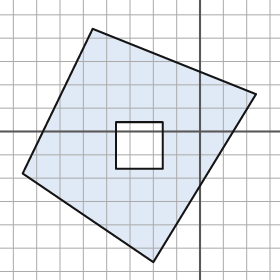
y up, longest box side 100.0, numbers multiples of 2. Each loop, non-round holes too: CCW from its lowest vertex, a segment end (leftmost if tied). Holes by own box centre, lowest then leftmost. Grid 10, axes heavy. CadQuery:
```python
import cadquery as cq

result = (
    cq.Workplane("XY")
    .moveTo(-20.0, -56.0)
    .lineTo(24.0, 16.0)
    .lineTo(-46.0, 44.0)
    .lineTo(-76.0, -18.0)
    .close()
    .moveTo(-36.0, -16.0)
    .lineTo(-16.0, -16.0)
    .lineTo(-16.0, 4.0)
    .lineTo(-36.0, 4.0)
    .close()
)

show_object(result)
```